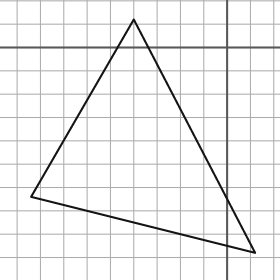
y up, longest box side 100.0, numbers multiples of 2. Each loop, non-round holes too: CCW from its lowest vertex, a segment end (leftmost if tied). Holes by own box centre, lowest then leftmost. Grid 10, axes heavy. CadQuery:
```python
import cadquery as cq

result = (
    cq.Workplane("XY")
    .moveTo(12.0, -88.0)
    .lineTo(-40.0, 12.0)
    .lineTo(-84.0, -64.0)
    .close()
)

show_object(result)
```